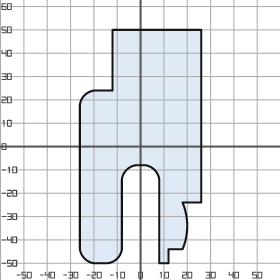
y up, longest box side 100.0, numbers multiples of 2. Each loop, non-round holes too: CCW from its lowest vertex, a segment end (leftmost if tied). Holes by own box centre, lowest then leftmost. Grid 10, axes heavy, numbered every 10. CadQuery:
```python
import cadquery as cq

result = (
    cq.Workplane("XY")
    .moveTo(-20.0, -50.0)
    .lineTo(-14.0, -50.0)
    .threePointArc((-10.0, -48.0), (-8.0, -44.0))
    .lineTo(-8.0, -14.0)
    .threePointArc((-6.0, -10.0), (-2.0, -8.0))
    .lineTo(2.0, -8.0)
    .threePointArc((6.0, -10.0), (8.0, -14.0))
    .lineTo(8.0, -50.0)
    .lineTo(12.0, -50.0)
    .lineTo(12.0, -44.0)
    .lineTo(18.0, -44.0)
    .threePointArc((20.0, -34.0), (18.0, -24.0))
    .lineTo(26.0, -24.0)
    .lineTo(26.0, 50.0)
    .lineTo(-12.0, 50.0)
    .lineTo(-12.0, 24.0)
    .lineTo(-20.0, 24.0)
    .threePointArc((-24.0, 22.0), (-26.0, 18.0))
    .lineTo(-26.0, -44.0)
    .threePointArc((-24.0, -48.0), (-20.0, -50.0))
    .close()
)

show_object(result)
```